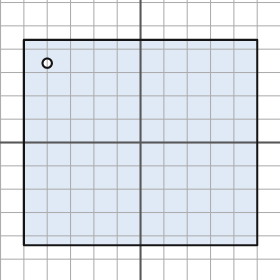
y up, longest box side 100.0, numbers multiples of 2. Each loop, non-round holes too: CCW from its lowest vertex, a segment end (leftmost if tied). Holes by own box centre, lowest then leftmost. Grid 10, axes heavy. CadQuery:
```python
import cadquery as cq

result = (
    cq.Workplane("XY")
    .moveTo(-50.0, -44.0)
    .lineTo(50.0, -44.0)
    .lineTo(50.0, 44.0)
    .lineTo(-50.0, 44.0)
    .close()
    .moveTo(-40.0, 34.0)
    .circle(2.0)
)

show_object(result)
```